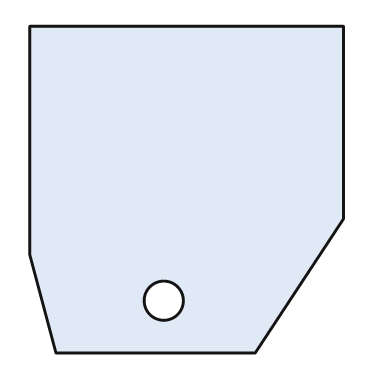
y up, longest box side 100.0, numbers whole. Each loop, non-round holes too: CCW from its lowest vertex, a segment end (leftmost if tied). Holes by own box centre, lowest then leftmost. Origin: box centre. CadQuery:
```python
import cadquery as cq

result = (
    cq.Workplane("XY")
    .moveTo(-40.0, -50.0)
    .lineTo(21.0, -50.0)
    .lineTo(48.0, -9.0)
    .lineTo(48.0, 50.0)
    .lineTo(-48.0, 50.0)
    .lineTo(-48.0, -20.0)
    .close()
    .moveTo(-7.0, -34.0)
    .circle(6.0)
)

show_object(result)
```